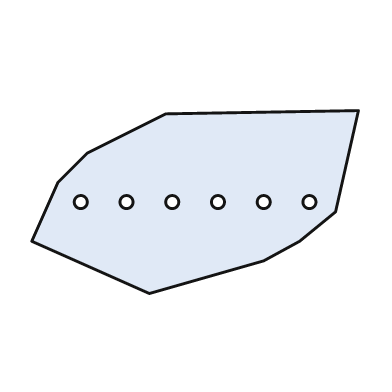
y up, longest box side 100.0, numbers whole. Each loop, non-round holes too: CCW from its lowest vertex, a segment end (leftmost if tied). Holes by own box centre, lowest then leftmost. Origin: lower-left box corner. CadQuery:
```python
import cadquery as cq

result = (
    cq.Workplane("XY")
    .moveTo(36.0, 0.0)
    .lineTo(71.0, 10.0)
    .lineTo(82.0, 16.0)
    .lineTo(93.0, 25.0)
    .lineTo(100.0, 56.0)
    .lineTo(41.0, 55.0)
    .lineTo(17.0, 43.0)
    .lineTo(8.0, 34.0)
    .lineTo(0.0, 16.0)
    .close()
    .moveTo(15.0, 28.0)
    .circle(2.0)
    .moveTo(29.0, 28.0)
    .circle(2.0)
    .moveTo(43.0, 28.0)
    .circle(2.0)
    .moveTo(57.0, 28.0)
    .circle(2.0)
    .moveTo(71.0, 28.0)
    .circle(2.0)
    .moveTo(85.0, 28.0)
    .circle(2.0)
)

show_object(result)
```